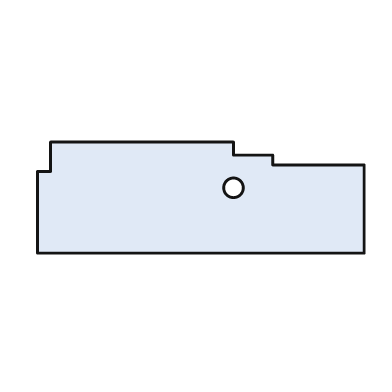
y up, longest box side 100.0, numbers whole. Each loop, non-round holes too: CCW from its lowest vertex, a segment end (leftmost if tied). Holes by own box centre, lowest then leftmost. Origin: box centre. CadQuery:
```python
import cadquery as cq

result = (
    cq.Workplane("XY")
    .moveTo(-50.0, -17.0)
    .lineTo(50.0, -17.0)
    .lineTo(50.0, 10.0)
    .lineTo(22.0, 10.0)
    .lineTo(22.0, 13.0)
    .lineTo(10.0, 13.0)
    .lineTo(10.0, 17.0)
    .lineTo(-46.0, 17.0)
    .lineTo(-46.0, 8.0)
    .lineTo(-50.0, 8.0)
    .close()
    .moveTo(10.0, 3.0)
    .circle(3.0)
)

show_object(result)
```